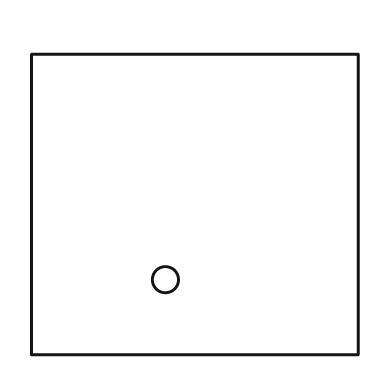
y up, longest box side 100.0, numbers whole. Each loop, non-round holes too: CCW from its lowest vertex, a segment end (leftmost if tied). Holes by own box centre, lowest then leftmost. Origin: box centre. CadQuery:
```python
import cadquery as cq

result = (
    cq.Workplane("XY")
    .moveTo(-50.0, -46.0)
    .lineTo(50.0, -46.0)
    .lineTo(50.0, 46.0)
    .lineTo(-50.0, 46.0)
    .close()
    .moveTo(-9.0, -23.0)
    .circle(4.0)
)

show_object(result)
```